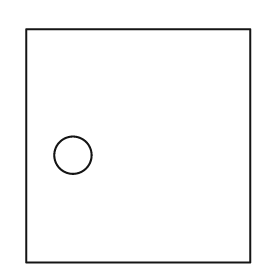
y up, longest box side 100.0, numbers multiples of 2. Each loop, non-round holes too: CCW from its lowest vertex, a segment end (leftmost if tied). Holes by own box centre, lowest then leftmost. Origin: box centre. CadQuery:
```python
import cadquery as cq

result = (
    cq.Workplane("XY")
    .moveTo(-48.0, -50.0)
    .lineTo(48.0, -50.0)
    .lineTo(48.0, 50.0)
    .lineTo(-48.0, 50.0)
    .close()
    .moveTo(-28.0, -4.0)
    .circle(8.0)
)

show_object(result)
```